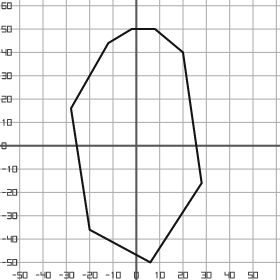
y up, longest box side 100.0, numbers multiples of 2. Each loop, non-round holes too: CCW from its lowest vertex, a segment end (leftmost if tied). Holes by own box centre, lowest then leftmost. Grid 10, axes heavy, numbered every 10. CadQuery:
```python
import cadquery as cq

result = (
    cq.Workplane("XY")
    .moveTo(6.0, -50.0)
    .lineTo(28.0, -16.0)
    .lineTo(20.0, 40.0)
    .lineTo(8.0, 50.0)
    .lineTo(-2.0, 50.0)
    .lineTo(-12.0, 44.0)
    .lineTo(-28.0, 16.0)
    .lineTo(-20.0, -36.0)
    .close()
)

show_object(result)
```